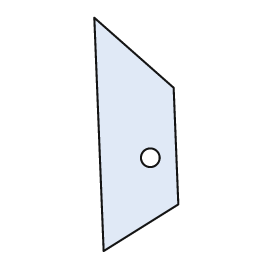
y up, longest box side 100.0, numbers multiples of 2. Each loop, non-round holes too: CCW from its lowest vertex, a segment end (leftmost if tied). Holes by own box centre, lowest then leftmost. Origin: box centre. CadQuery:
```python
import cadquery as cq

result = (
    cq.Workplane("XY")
    .moveTo(-14.0, -50.0)
    .lineTo(18.0, -30.0)
    .lineTo(16.0, 20.0)
    .lineTo(-18.0, 50.0)
    .close()
    .moveTo(6.0, -10.0)
    .circle(4.0)
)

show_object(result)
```